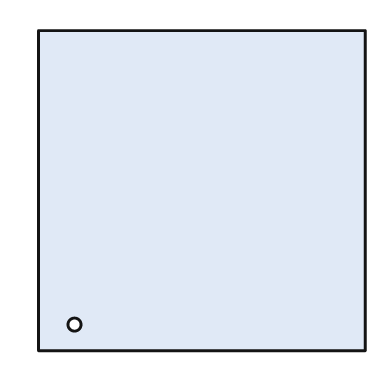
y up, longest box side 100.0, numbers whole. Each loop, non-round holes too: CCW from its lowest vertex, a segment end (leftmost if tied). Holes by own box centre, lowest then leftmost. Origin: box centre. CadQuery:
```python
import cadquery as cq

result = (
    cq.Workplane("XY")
    .moveTo(-50.0, -49.0)
    .lineTo(50.0, -49.0)
    .lineTo(50.0, 49.0)
    .lineTo(-50.0, 49.0)
    .close()
    .moveTo(-39.0, -41.0)
    .circle(2.0)
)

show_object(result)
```